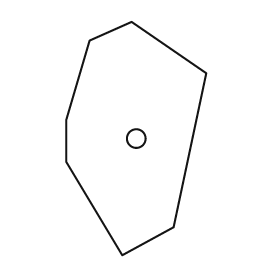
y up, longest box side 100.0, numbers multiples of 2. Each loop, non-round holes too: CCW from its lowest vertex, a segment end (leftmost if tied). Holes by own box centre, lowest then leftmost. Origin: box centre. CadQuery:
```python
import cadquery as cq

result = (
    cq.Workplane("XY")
    .moveTo(-6.0, -50.0)
    .lineTo(16.0, -38.0)
    .lineTo(30.0, 28.0)
    .lineTo(-2.0, 50.0)
    .lineTo(-20.0, 42.0)
    .lineTo(-30.0, 8.0)
    .lineTo(-30.0, -10.0)
    .close()
    .moveTo(0.0, 0.0)
    .circle(4.0)
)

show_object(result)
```